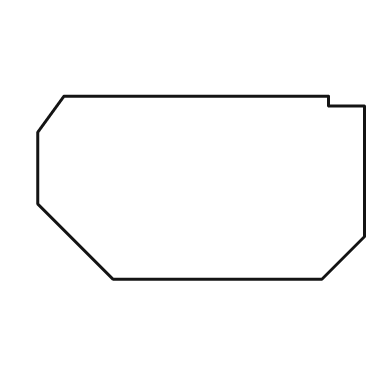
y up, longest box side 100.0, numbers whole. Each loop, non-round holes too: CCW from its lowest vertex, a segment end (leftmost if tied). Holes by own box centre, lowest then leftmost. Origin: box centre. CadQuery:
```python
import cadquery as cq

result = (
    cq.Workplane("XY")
    .moveTo(-27.0, -28.0)
    .lineTo(37.0, -28.0)
    .lineTo(50.0, -15.0)
    .lineTo(50.0, 25.0)
    .lineTo(39.0, 25.0)
    .lineTo(39.0, 28.0)
    .lineTo(-42.0, 28.0)
    .lineTo(-50.0, 17.0)
    .lineTo(-50.0, -5.0)
    .close()
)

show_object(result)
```